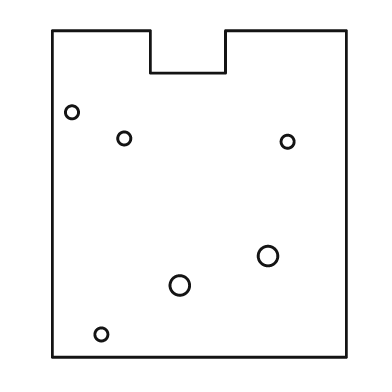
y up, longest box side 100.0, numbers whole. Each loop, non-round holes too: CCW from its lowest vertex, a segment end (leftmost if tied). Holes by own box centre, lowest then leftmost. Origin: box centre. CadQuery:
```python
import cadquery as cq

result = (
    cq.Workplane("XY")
    .moveTo(-45.0, -50.0)
    .lineTo(45.0, -50.0)
    .lineTo(45.0, 50.0)
    .lineTo(8.0, 50.0)
    .lineTo(8.0, 37.0)
    .lineTo(-15.0, 37.0)
    .lineTo(-15.0, 50.0)
    .lineTo(-45.0, 50.0)
    .close()
    .moveTo(-30.0, -43.0)
    .circle(2.0)
    .moveTo(-6.0, -28.0)
    .circle(3.0)
    .moveTo(21.0, -19.0)
    .circle(3.0)
    .moveTo(27.0, 16.0)
    .circle(2.0)
    .moveTo(-23.0, 17.0)
    .circle(2.0)
    .moveTo(-39.0, 25.0)
    .circle(2.0)
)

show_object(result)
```